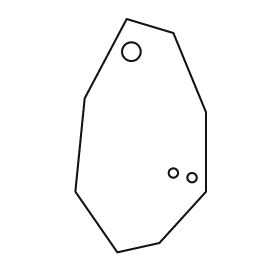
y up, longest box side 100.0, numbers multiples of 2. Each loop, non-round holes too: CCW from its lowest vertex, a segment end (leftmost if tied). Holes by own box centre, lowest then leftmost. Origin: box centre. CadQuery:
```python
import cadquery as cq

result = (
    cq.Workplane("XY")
    .moveTo(-10.0, -50.0)
    .lineTo(8.0, -46.0)
    .lineTo(28.0, -24.0)
    .lineTo(28.0, 10.0)
    .lineTo(14.0, 44.0)
    .lineTo(-6.0, 50.0)
    .lineTo(-24.0, 16.0)
    .lineTo(-28.0, -24.0)
    .close()
    .moveTo(22.0, -18.0)
    .circle(2.0)
    .moveTo(14.0, -16.0)
    .circle(2.0)
    .moveTo(-4.0, 36.0)
    .circle(4.0)
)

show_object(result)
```